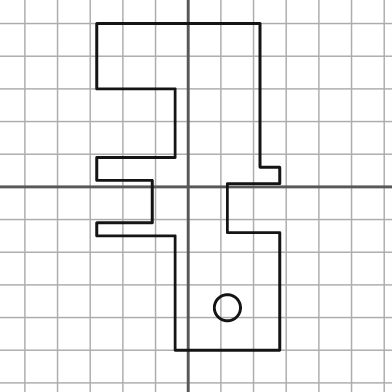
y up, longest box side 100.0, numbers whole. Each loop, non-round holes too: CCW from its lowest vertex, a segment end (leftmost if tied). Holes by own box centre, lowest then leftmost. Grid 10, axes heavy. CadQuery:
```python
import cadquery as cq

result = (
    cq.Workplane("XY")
    .moveTo(-4.0, -50.0)
    .lineTo(28.0, -50.0)
    .lineTo(28.0, -14.0)
    .lineTo(12.0, -14.0)
    .lineTo(12.0, 1.0)
    .lineTo(28.0, 1.0)
    .lineTo(28.0, 6.0)
    .lineTo(22.0, 6.0)
    .lineTo(22.0, 50.0)
    .lineTo(-28.0, 50.0)
    .lineTo(-28.0, 30.0)
    .lineTo(-4.0, 30.0)
    .lineTo(-4.0, 9.0)
    .lineTo(-28.0, 9.0)
    .lineTo(-28.0, 2.0)
    .lineTo(-11.0, 2.0)
    .lineTo(-11.0, -11.0)
    .lineTo(-28.0, -11.0)
    .lineTo(-28.0, -15.0)
    .lineTo(-4.0, -15.0)
    .close()
    .moveTo(12.0, -37.0)
    .circle(4.0)
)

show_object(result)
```